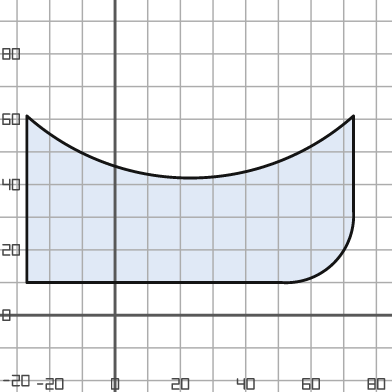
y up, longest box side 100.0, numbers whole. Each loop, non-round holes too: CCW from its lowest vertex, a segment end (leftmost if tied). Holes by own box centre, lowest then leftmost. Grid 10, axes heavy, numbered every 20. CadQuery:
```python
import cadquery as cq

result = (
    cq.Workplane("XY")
    .moveTo(-27.0, 10.0)
    .lineTo(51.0, 10.0)
    .threePointArc((67.0, 16.0), (73.0, 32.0))
    .lineTo(73.0, 61.0)
    .threePointArc((23.0, 42.0), (-27.0, 61.0))
    .close()
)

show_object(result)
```